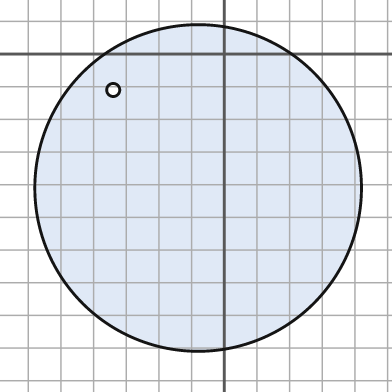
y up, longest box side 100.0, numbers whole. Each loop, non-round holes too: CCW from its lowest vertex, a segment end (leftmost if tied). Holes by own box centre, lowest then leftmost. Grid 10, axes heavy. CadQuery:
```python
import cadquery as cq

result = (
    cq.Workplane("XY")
    .moveTo(-8.0, -41.0)
    .circle(50.0)
    .moveTo(-34.0, -11.0)
    .circle(2.0)
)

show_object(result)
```